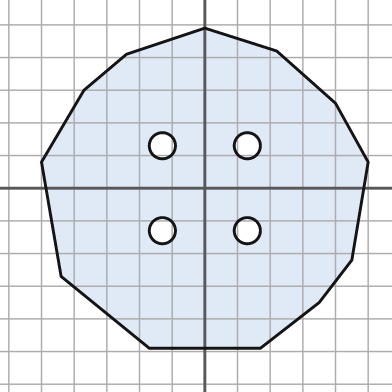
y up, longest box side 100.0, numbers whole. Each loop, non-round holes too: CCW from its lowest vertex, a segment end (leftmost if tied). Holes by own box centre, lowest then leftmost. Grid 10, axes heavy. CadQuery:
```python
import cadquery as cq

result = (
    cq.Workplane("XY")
    .moveTo(-17.0, -49.0)
    .lineTo(17.0, -49.0)
    .lineTo(35.0, -35.0)
    .lineTo(45.0, -22.0)
    .lineTo(50.0, 8.0)
    .lineTo(40.0, 26.0)
    .lineTo(22.0, 42.0)
    .lineTo(0.0, 49.0)
    .lineTo(-24.0, 41.0)
    .lineTo(-37.0, 30.0)
    .lineTo(-50.0, 8.0)
    .lineTo(-44.0, -27.0)
    .close()
    .moveTo(-13.0, -13.0)
    .circle(4.0)
    .moveTo(13.0, -13.0)
    .circle(4.0)
    .moveTo(-13.0, 13.0)
    .circle(4.0)
    .moveTo(13.0, 13.0)
    .circle(4.0)
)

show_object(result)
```